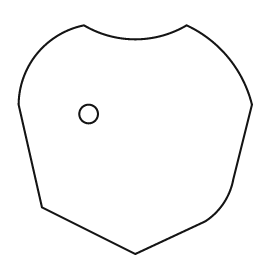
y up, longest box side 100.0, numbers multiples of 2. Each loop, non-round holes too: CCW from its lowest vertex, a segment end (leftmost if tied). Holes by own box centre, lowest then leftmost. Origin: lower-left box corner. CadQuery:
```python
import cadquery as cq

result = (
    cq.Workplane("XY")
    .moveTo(50.0, 0.0)
    .lineTo(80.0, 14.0)
    .threePointArc((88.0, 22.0), (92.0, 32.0))
    .lineTo(100.0, 64.0)
    .threePointArc((90.0, 84.0), (72.0, 98.0))
    .threePointArc((50.0, 92.0), (28.0, 98.0))
    .threePointArc((8.0, 86.0), (0.0, 64.0))
    .lineTo(10.0, 20.0)
    .close()
    .moveTo(30.0, 60.0)
    .circle(4.0)
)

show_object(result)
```